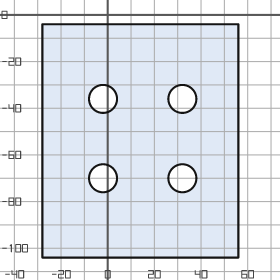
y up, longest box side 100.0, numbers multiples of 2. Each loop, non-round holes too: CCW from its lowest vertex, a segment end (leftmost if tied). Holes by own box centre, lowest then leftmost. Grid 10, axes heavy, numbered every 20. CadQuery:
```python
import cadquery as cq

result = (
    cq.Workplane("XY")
    .moveTo(-28.0, -104.0)
    .lineTo(56.0, -104.0)
    .lineTo(56.0, -4.0)
    .lineTo(-28.0, -4.0)
    .close()
    .moveTo(-2.0, -70.0)
    .circle(6.0)
    .moveTo(32.0, -70.0)
    .circle(6.0)
    .moveTo(-2.0, -36.0)
    .circle(6.0)
    .moveTo(32.0, -36.0)
    .circle(6.0)
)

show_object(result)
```